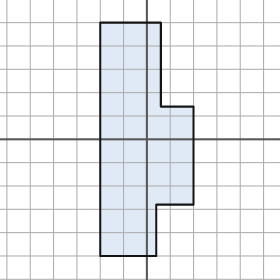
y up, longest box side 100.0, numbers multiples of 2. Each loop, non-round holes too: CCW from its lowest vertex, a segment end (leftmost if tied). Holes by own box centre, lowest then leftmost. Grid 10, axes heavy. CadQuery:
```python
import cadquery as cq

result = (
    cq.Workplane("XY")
    .moveTo(-20.0, -50.0)
    .lineTo(4.0, -50.0)
    .lineTo(4.0, -28.0)
    .lineTo(20.0, -28.0)
    .lineTo(20.0, 14.0)
    .lineTo(6.0, 14.0)
    .lineTo(6.0, 50.0)
    .lineTo(-20.0, 50.0)
    .close()
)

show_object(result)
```